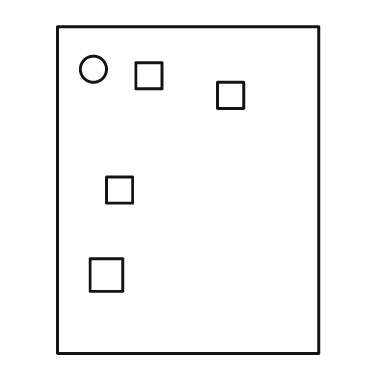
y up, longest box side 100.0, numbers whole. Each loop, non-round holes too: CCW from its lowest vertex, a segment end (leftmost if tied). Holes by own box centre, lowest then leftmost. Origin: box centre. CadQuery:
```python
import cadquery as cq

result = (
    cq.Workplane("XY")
    .moveTo(-40.0, -50.0)
    .lineTo(40.0, -50.0)
    .lineTo(40.0, 50.0)
    .lineTo(-40.0, 50.0)
    .close()
    .moveTo(-30.0, -31.0)
    .lineTo(-20.0, -31.0)
    .lineTo(-20.0, -21.0)
    .lineTo(-30.0, -21.0)
    .close()
    .moveTo(-25.0, -4.0)
    .lineTo(-17.0, -4.0)
    .lineTo(-17.0, 4.0)
    .lineTo(-25.0, 4.0)
    .close()
    .moveTo(9.0, 25.0)
    .lineTo(17.0, 25.0)
    .lineTo(17.0, 33.0)
    .lineTo(9.0, 33.0)
    .close()
    .moveTo(-16.0, 31.0)
    .lineTo(-8.0, 31.0)
    .lineTo(-8.0, 39.0)
    .lineTo(-16.0, 39.0)
    .close()
    .moveTo(-29.0, 37.0)
    .circle(4.0)
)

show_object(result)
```